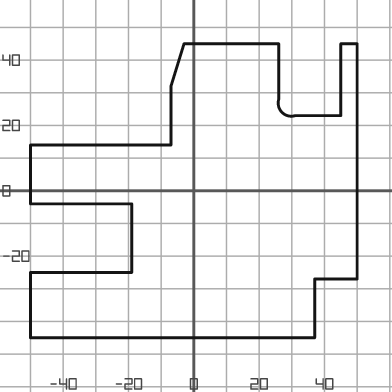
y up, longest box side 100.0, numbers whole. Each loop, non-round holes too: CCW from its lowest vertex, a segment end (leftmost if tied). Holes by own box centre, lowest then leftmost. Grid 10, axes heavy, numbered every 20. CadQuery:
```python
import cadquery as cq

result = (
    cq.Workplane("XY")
    .moveTo(-50.0, -45.0)
    .lineTo(37.0, -45.0)
    .lineTo(37.0, -27.0)
    .lineTo(50.0, -27.0)
    .lineTo(50.0, 45.0)
    .lineTo(45.0, 45.0)
    .lineTo(45.0, 23.0)
    .lineTo(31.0, 23.0)
    .threePointArc((27.0, 24.0), (26.0, 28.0))
    .lineTo(26.0, 45.0)
    .lineTo(-3.0, 45.0)
    .lineTo(-7.0, 32.0)
    .lineTo(-7.0, 14.0)
    .lineTo(-50.0, 14.0)
    .lineTo(-50.0, -4.0)
    .lineTo(-19.0, -4.0)
    .lineTo(-19.0, -25.0)
    .lineTo(-50.0, -25.0)
    .close()
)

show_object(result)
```